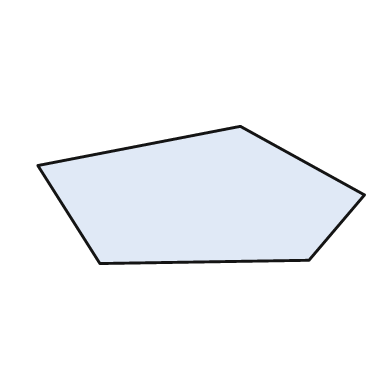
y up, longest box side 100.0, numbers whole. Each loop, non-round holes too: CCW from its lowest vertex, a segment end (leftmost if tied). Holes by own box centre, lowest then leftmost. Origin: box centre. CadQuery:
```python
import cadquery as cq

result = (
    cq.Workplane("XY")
    .moveTo(-31.0, -21.0)
    .lineTo(33.0, -20.0)
    .lineTo(50.0, 0.0)
    .lineTo(12.0, 21.0)
    .lineTo(-50.0, 9.0)
    .close()
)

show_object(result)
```